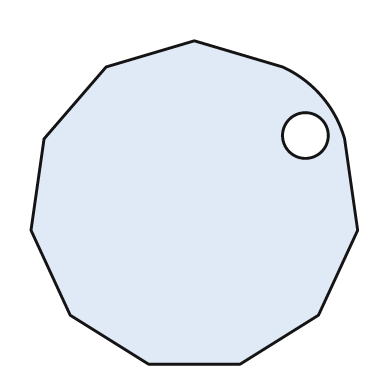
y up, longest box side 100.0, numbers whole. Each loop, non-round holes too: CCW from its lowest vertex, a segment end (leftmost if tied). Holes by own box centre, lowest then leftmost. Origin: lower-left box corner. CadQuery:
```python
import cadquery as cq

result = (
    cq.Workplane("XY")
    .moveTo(36.0, 0.0)
    .lineTo(64.0, 0.0)
    .lineTo(88.0, 15.0)
    .lineTo(100.0, 41.0)
    .lineTo(96.0, 69.0)
    .threePointArc((89.0, 82.0), (77.0, 91.0))
    .lineTo(50.0, 99.0)
    .lineTo(23.0, 91.0)
    .lineTo(4.0, 69.0)
    .lineTo(0.0, 41.0)
    .lineTo(12.0, 15.0)
    .close()
    .moveTo(84.0, 70.0)
    .circle(7.0)
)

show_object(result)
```